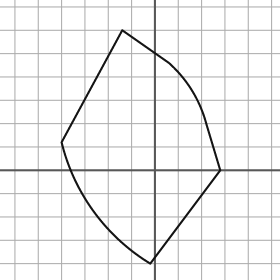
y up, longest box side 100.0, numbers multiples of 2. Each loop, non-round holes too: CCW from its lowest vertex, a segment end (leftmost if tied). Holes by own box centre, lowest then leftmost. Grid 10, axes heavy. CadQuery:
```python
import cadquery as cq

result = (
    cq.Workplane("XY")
    .moveTo(-2.0, -40.0)
    .lineTo(28.0, 0.0)
    .lineTo(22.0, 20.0)
    .threePointArc((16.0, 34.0), (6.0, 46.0))
    .lineTo(-14.0, 60.0)
    .lineTo(-40.0, 12.0)
    .threePointArc((-26.0, -18.0), (-2.0, -40.0))
    .close()
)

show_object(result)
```